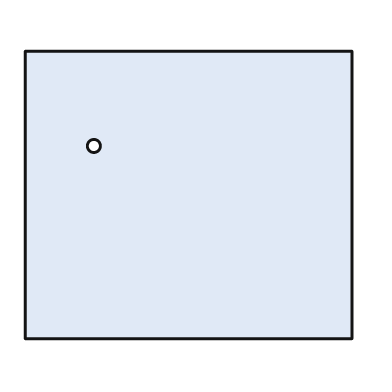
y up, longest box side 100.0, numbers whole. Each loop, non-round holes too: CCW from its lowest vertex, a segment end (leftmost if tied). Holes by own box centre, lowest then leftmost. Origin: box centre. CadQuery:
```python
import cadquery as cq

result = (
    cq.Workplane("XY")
    .moveTo(-50.0, -44.0)
    .lineTo(50.0, -44.0)
    .lineTo(50.0, 44.0)
    .lineTo(-50.0, 44.0)
    .close()
    .moveTo(-29.0, 15.0)
    .circle(2.0)
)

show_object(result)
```